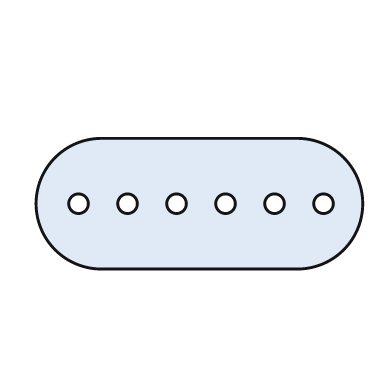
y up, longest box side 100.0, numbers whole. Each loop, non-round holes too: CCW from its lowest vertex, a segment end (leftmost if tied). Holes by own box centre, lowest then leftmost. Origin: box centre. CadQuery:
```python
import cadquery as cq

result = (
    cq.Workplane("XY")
    .moveTo(-30.0, -20.0)
    .lineTo(30.0, -20.0)
    .threePointArc((50.0, 0.0), (30.0, 20.0))
    .lineTo(-30.0, 20.0)
    .threePointArc((-50.0, 0.0), (-30.0, -20.0))
    .close()
    .moveTo(-37.0, 0.0)
    .circle(3.0)
    .moveTo(-22.0, 0.0)
    .circle(3.0)
    .moveTo(-7.0, 0.0)
    .circle(3.0)
    .moveTo(8.0, 0.0)
    .circle(3.0)
    .moveTo(23.0, 0.0)
    .circle(3.0)
    .moveTo(38.0, 0.0)
    .circle(3.0)
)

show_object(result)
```